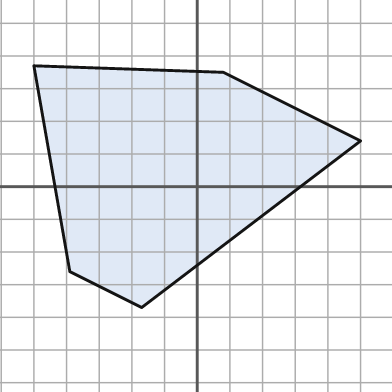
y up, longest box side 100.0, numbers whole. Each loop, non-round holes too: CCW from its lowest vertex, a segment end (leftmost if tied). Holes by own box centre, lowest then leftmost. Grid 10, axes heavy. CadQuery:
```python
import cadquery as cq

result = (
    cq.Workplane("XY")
    .moveTo(-17.0, -37.0)
    .lineTo(50.0, 14.0)
    .lineTo(8.0, 35.0)
    .lineTo(-50.0, 37.0)
    .lineTo(-39.0, -26.0)
    .close()
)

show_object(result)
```